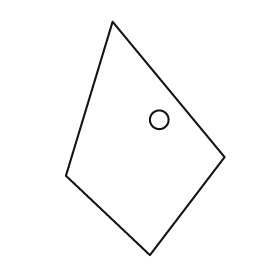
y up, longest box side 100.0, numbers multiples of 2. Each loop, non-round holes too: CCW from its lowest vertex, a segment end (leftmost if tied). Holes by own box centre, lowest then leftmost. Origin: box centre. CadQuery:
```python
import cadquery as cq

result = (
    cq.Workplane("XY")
    .moveTo(2.0, -50.0)
    .lineTo(34.0, -8.0)
    .lineTo(-14.0, 50.0)
    .lineTo(-34.0, -16.0)
    .close()
    .moveTo(6.0, 8.0)
    .circle(4.0)
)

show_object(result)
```